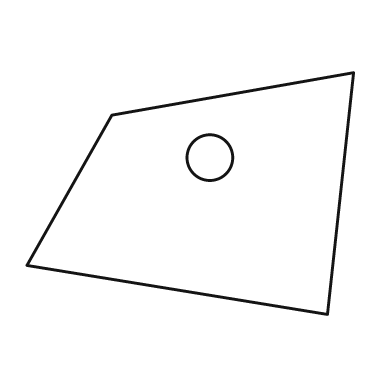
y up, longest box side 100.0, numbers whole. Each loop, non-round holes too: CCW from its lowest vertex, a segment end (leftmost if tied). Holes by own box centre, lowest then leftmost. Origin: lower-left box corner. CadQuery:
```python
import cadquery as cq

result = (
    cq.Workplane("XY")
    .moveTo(92.0, 0.0)
    .lineTo(100.0, 74.0)
    .lineTo(26.0, 61.0)
    .lineTo(0.0, 15.0)
    .close()
    .moveTo(56.0, 48.0)
    .circle(7.0)
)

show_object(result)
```